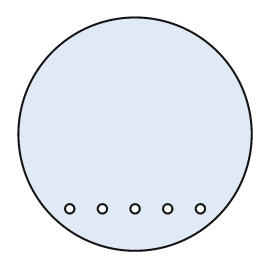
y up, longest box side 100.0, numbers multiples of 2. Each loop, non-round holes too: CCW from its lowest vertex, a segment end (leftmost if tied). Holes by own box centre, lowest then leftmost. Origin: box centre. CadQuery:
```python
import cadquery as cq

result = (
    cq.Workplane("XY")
    .moveTo(0.0, 0.0)
    .circle(50.0)
    .moveTo(-28.0, -32.0)
    .circle(2.0)
    .moveTo(-14.0, -32.0)
    .circle(2.0)
    .moveTo(0.0, -32.0)
    .circle(2.0)
    .moveTo(14.0, -32.0)
    .circle(2.0)
    .moveTo(28.0, -32.0)
    .circle(2.0)
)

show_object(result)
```